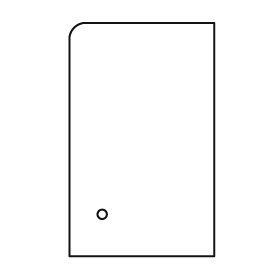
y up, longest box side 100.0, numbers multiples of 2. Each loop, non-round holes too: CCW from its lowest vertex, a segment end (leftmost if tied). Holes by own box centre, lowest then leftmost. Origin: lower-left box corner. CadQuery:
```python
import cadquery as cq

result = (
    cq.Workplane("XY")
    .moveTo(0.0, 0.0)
    .lineTo(62.0, 0.0)
    .lineTo(62.0, 100.0)
    .lineTo(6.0, 100.0)
    .threePointArc((2.0, 98.0), (0.0, 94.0))
    .close()
    .moveTo(14.0, 18.0)
    .circle(2.0)
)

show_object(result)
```